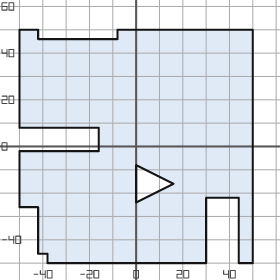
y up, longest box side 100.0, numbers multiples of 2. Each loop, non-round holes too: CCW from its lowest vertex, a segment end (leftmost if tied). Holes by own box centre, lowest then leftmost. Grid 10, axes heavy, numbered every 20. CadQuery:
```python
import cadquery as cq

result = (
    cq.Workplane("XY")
    .moveTo(-38.0, -50.0)
    .lineTo(30.0, -50.0)
    .lineTo(30.0, -22.0)
    .lineTo(44.0, -22.0)
    .lineTo(44.0, -50.0)
    .lineTo(50.0, -50.0)
    .lineTo(50.0, 50.0)
    .lineTo(-8.0, 50.0)
    .lineTo(-8.0, 46.0)
    .lineTo(-42.0, 46.0)
    .lineTo(-42.0, 50.0)
    .lineTo(-50.0, 50.0)
    .lineTo(-50.0, 8.0)
    .lineTo(-16.0, 8.0)
    .lineTo(-16.0, -2.0)
    .lineTo(-50.0, -2.0)
    .lineTo(-50.0, -26.0)
    .lineTo(-42.0, -26.0)
    .lineTo(-42.0, -46.0)
    .lineTo(-38.0, -46.0)
    .close()
    .moveTo(0.0, -24.0)
    .lineTo(16.0, -16.0)
    .lineTo(0.0, -8.0)
    .close()
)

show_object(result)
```